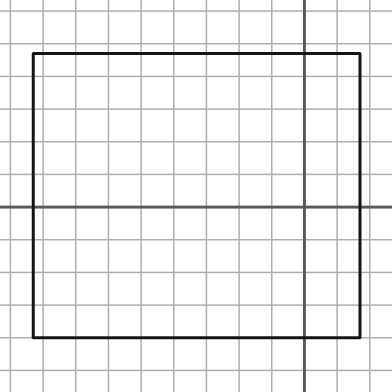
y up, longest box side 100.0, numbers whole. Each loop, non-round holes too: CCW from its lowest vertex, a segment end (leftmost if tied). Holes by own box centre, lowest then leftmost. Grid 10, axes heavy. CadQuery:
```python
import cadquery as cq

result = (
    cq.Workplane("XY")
    .moveTo(-83.0, -40.0)
    .lineTo(17.0, -40.0)
    .lineTo(17.0, 47.0)
    .lineTo(-83.0, 47.0)
    .close()
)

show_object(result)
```